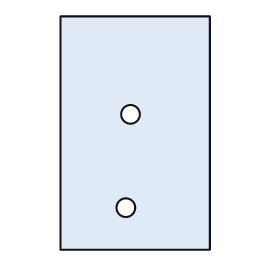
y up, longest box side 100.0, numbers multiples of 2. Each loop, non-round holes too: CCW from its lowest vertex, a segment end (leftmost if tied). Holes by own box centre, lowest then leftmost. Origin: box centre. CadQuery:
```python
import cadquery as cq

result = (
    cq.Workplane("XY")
    .moveTo(-32.0, -50.0)
    .lineTo(32.0, -50.0)
    .lineTo(32.0, 50.0)
    .lineTo(-32.0, 50.0)
    .close()
    .moveTo(-4.0, -32.0)
    .circle(4.0)
    .moveTo(-2.0, 8.0)
    .circle(4.0)
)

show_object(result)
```